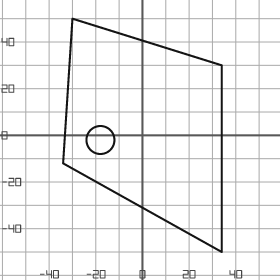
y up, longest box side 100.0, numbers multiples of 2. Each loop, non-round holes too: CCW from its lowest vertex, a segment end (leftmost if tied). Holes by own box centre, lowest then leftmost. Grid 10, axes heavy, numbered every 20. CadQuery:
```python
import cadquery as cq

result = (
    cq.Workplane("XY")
    .moveTo(34.0, -50.0)
    .lineTo(34.0, 30.0)
    .lineTo(-30.0, 50.0)
    .lineTo(-34.0, -12.0)
    .close()
    .moveTo(-18.0, -2.0)
    .circle(6.0)
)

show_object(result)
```